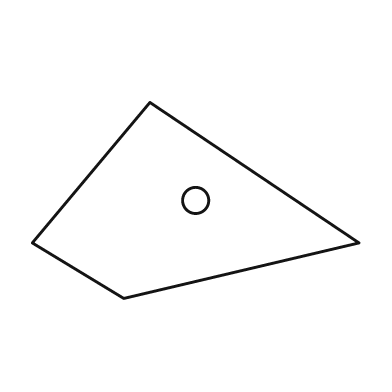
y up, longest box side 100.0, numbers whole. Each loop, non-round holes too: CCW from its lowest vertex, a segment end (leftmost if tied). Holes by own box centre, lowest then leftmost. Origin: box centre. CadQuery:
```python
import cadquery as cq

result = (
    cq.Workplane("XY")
    .moveTo(-22.0, -30.0)
    .lineTo(50.0, -13.0)
    .lineTo(-14.0, 30.0)
    .lineTo(-50.0, -13.0)
    .close()
    .moveTo(0.0, 0.0)
    .circle(4.0)
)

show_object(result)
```